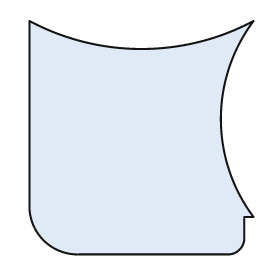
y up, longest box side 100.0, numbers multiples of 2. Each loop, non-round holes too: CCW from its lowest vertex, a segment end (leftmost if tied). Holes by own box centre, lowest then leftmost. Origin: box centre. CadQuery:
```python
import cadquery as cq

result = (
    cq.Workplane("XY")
    .moveTo(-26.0, -50.0)
    .lineTo(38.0, -50.0)
    .threePointArc((42.0, -48.0), (44.0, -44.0))
    .lineTo(44.0, -34.0)
    .lineTo(48.0, -34.0)
    .threePointArc((34.0, 8.0), (48.0, 50.0))
    .threePointArc((0.0, 38.0), (-48.0, 50.0))
    .lineTo(-48.0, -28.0)
    .threePointArc((-42.0, -44.0), (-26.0, -50.0))
    .close()
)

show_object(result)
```